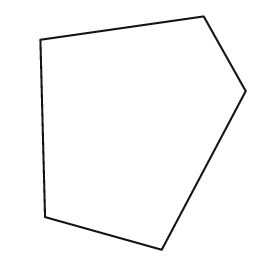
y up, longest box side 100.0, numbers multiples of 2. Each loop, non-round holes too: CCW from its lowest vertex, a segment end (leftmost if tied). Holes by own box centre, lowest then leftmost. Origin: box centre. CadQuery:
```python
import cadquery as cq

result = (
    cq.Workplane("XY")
    .moveTo(8.0, -50.0)
    .lineTo(44.0, 18.0)
    .lineTo(26.0, 50.0)
    .lineTo(-44.0, 40.0)
    .lineTo(-42.0, -36.0)
    .close()
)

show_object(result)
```